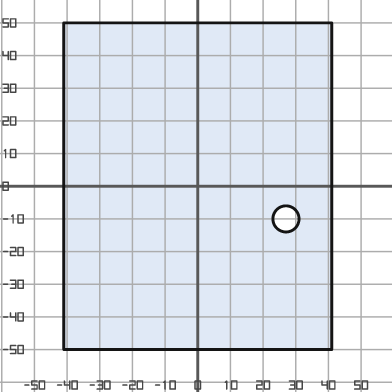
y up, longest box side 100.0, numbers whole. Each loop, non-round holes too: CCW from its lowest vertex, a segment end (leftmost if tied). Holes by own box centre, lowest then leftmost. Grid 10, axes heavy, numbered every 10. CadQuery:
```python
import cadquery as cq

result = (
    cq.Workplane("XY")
    .moveTo(-41.0, -50.0)
    .lineTo(41.0, -50.0)
    .lineTo(41.0, 50.0)
    .lineTo(-41.0, 50.0)
    .close()
    .moveTo(27.0, -10.0)
    .circle(4.0)
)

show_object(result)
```